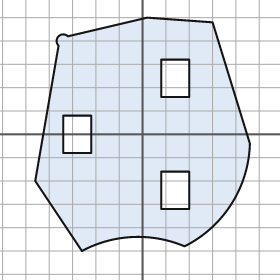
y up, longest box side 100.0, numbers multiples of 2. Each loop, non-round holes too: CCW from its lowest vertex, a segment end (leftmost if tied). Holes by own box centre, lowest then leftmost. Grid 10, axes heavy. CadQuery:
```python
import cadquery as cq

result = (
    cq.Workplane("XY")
    .moveTo(-26.0, -50.0)
    .threePointArc((-4.0, -44.0), (18.0, -48.0))
    .threePointArc((38.0, -30.0), (46.0, -4.0))
    .lineTo(30.0, 48.0)
    .lineTo(2.0, 50.0)
    .lineTo(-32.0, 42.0)
    .threePointArc((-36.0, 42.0), (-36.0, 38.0))
    .lineTo(-46.0, -20.0)
    .close()
    .moveTo(8.0, -32.0)
    .lineTo(20.0, -32.0)
    .lineTo(20.0, -16.0)
    .lineTo(8.0, -16.0)
    .close()
    .moveTo(-34.0, -8.0)
    .lineTo(-22.0, -8.0)
    .lineTo(-22.0, 8.0)
    .lineTo(-34.0, 8.0)
    .close()
    .moveTo(8.0, 16.0)
    .lineTo(20.0, 16.0)
    .lineTo(20.0, 32.0)
    .lineTo(8.0, 32.0)
    .close()
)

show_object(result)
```